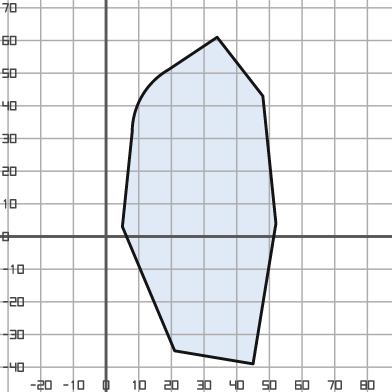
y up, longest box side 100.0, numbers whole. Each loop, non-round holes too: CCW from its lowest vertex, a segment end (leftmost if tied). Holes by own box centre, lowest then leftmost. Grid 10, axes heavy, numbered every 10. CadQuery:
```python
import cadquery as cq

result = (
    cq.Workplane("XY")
    .moveTo(45.0, -39.0)
    .lineTo(52.0, 4.0)
    .lineTo(48.0, 43.0)
    .lineTo(34.0, 61.0)
    .lineTo(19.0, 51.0)
    .threePointArc((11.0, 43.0), (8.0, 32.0))
    .lineTo(5.0, 3.0)
    .lineTo(21.0, -35.0)
    .close()
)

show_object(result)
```